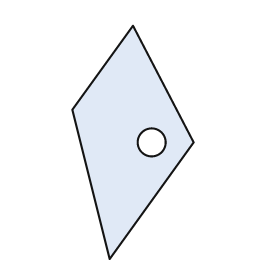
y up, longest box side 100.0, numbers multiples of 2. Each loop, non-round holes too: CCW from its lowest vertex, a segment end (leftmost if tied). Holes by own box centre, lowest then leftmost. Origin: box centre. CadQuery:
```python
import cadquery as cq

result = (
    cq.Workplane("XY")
    .moveTo(-10.0, -50.0)
    .lineTo(26.0, 0.0)
    .lineTo(0.0, 50.0)
    .lineTo(-26.0, 14.0)
    .close()
    .moveTo(8.0, 0.0)
    .circle(6.0)
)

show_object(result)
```